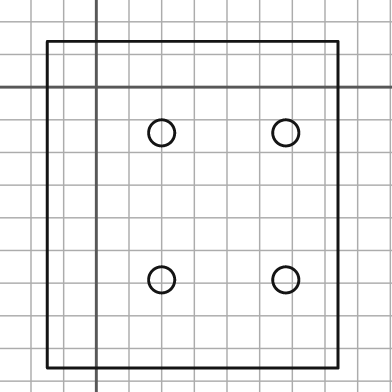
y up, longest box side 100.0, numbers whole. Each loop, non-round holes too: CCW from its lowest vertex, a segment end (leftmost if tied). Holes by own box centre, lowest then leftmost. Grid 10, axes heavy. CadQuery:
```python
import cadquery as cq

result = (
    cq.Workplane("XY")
    .moveTo(-15.0, -86.0)
    .lineTo(74.0, -86.0)
    .lineTo(74.0, 14.0)
    .lineTo(-15.0, 14.0)
    .close()
    .moveTo(20.0, -59.0)
    .circle(4.0)
    .moveTo(58.0, -59.0)
    .circle(4.0)
    .moveTo(20.0, -14.0)
    .circle(4.0)
    .moveTo(58.0, -14.0)
    .circle(4.0)
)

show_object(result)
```